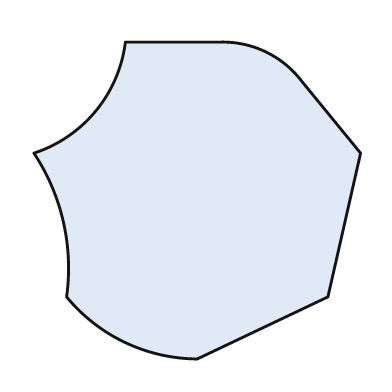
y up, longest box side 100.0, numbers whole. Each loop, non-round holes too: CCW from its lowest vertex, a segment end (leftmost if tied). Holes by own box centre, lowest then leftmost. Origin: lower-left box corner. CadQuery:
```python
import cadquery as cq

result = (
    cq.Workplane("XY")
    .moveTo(50.0, 0.0)
    .lineTo(90.0, 19.0)
    .lineTo(100.0, 63.0)
    .lineTo(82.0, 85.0)
    .threePointArc((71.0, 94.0), (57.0, 97.0))
    .lineTo(28.0, 97.0)
    .threePointArc((19.0, 76.0), (0.0, 63.0))
    .threePointArc((9.0, 42.0), (10.0, 19.0))
    .threePointArc((28.0, 5.0), (50.0, 0.0))
    .close()
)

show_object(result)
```